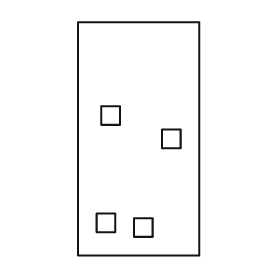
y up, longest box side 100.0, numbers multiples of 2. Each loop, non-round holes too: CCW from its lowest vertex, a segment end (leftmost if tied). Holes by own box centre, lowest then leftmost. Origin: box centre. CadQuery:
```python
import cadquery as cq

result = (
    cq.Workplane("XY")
    .moveTo(-26.0, -50.0)
    .lineTo(26.0, -50.0)
    .lineTo(26.0, 50.0)
    .lineTo(-26.0, 50.0)
    .close()
    .moveTo(-2.0, -42.0)
    .lineTo(6.0, -42.0)
    .lineTo(6.0, -34.0)
    .lineTo(-2.0, -34.0)
    .close()
    .moveTo(-18.0, -40.0)
    .lineTo(-10.0, -40.0)
    .lineTo(-10.0, -32.0)
    .lineTo(-18.0, -32.0)
    .close()
    .moveTo(10.0, -4.0)
    .lineTo(18.0, -4.0)
    .lineTo(18.0, 4.0)
    .lineTo(10.0, 4.0)
    .close()
    .moveTo(-16.0, 6.0)
    .lineTo(-8.0, 6.0)
    .lineTo(-8.0, 14.0)
    .lineTo(-16.0, 14.0)
    .close()
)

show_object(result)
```